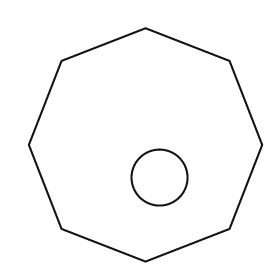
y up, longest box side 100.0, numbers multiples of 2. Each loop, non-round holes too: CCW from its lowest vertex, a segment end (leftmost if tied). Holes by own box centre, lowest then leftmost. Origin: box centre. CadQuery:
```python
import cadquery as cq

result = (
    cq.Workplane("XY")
    .moveTo(0.0, -50.0)
    .lineTo(36.0, -36.0)
    .lineTo(50.0, 0.0)
    .lineTo(36.0, 36.0)
    .lineTo(0.0, 50.0)
    .lineTo(-36.0, 36.0)
    .lineTo(-50.0, 0.0)
    .lineTo(-36.0, -36.0)
    .close()
    .moveTo(6.0, -14.0)
    .circle(12.0)
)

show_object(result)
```